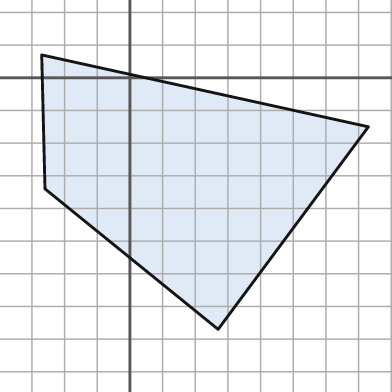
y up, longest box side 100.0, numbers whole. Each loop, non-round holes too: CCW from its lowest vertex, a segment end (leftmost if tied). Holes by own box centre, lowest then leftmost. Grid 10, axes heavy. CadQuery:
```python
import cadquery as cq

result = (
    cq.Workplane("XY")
    .moveTo(27.0, -77.0)
    .lineTo(73.0, -15.0)
    .lineTo(-27.0, 7.0)
    .lineTo(-26.0, -34.0)
    .close()
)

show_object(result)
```